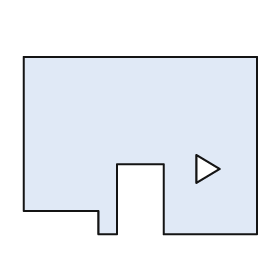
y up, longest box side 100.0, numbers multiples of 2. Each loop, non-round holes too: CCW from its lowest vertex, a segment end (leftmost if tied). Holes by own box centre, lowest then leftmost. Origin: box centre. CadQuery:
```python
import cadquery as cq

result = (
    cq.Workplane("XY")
    .moveTo(-18.0, -38.0)
    .lineTo(-10.0, -38.0)
    .lineTo(-10.0, -8.0)
    .lineTo(10.0, -8.0)
    .lineTo(10.0, -38.0)
    .lineTo(50.0, -38.0)
    .lineTo(50.0, 38.0)
    .lineTo(-50.0, 38.0)
    .lineTo(-50.0, -28.0)
    .lineTo(-18.0, -28.0)
    .close()
    .moveTo(24.0, -16.0)
    .lineTo(34.0, -10.0)
    .lineTo(24.0, -4.0)
    .close()
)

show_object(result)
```